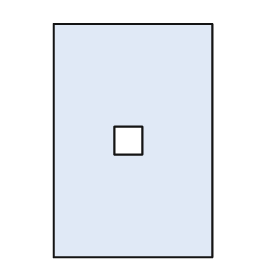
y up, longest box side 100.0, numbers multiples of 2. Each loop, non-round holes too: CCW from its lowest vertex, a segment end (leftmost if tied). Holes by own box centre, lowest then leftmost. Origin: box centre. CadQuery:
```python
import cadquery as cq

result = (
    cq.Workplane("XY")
    .moveTo(-34.0, -50.0)
    .lineTo(34.0, -50.0)
    .lineTo(34.0, 50.0)
    .lineTo(-34.0, 50.0)
    .close()
    .moveTo(-8.0, -6.0)
    .lineTo(4.0, -6.0)
    .lineTo(4.0, 6.0)
    .lineTo(-8.0, 6.0)
    .close()
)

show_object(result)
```